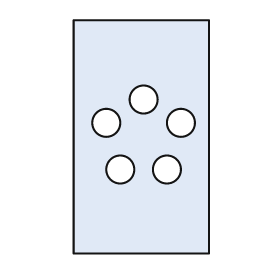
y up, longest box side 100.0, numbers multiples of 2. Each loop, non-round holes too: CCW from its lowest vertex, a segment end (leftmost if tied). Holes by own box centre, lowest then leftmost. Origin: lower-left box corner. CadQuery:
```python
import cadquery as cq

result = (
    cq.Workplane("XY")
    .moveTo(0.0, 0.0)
    .lineTo(58.0, 0.0)
    .lineTo(58.0, 100.0)
    .lineTo(0.0, 100.0)
    .close()
    .moveTo(20.0, 36.0)
    .circle(6.0)
    .moveTo(40.0, 36.0)
    .circle(6.0)
    .moveTo(14.0, 56.0)
    .circle(6.0)
    .moveTo(46.0, 56.0)
    .circle(6.0)
    .moveTo(30.0, 66.0)
    .circle(6.0)
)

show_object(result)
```